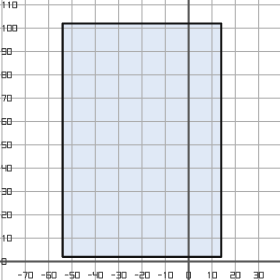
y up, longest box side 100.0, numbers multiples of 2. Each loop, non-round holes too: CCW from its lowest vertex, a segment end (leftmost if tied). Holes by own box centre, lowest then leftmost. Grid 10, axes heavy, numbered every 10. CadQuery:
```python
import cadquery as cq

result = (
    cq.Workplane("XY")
    .moveTo(-54.0, 2.0)
    .lineTo(14.0, 2.0)
    .lineTo(14.0, 102.0)
    .lineTo(-54.0, 102.0)
    .close()
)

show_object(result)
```